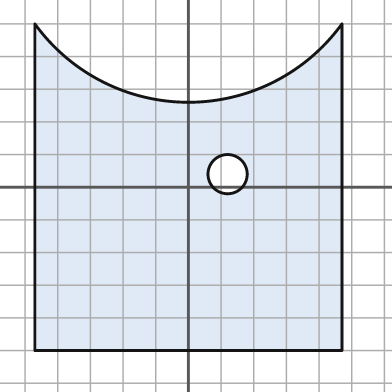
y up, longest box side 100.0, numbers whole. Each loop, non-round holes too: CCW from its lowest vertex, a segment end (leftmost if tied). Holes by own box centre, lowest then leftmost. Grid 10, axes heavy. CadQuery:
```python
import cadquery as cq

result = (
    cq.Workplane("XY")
    .moveTo(-47.0, -50.0)
    .lineTo(47.0, -50.0)
    .lineTo(47.0, 50.0)
    .threePointArc((0.0, 26.0), (-47.0, 50.0))
    .close()
    .moveTo(12.0, 4.0)
    .circle(6.0)
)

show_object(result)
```